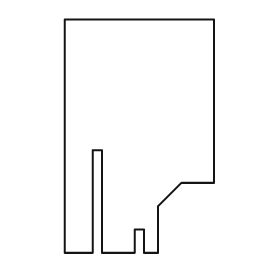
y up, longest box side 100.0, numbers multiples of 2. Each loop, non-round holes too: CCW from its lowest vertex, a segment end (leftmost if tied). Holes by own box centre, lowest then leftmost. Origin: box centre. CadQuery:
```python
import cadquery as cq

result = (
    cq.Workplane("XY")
    .moveTo(-32.0, -50.0)
    .lineTo(-20.0, -50.0)
    .lineTo(-20.0, -6.0)
    .lineTo(-16.0, -6.0)
    .lineTo(-16.0, -50.0)
    .lineTo(-2.0, -50.0)
    .lineTo(-2.0, -40.0)
    .lineTo(2.0, -40.0)
    .lineTo(2.0, -50.0)
    .lineTo(8.0, -50.0)
    .lineTo(8.0, -30.0)
    .lineTo(18.0, -20.0)
    .lineTo(32.0, -20.0)
    .lineTo(32.0, 50.0)
    .lineTo(-32.0, 50.0)
    .close()
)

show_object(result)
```